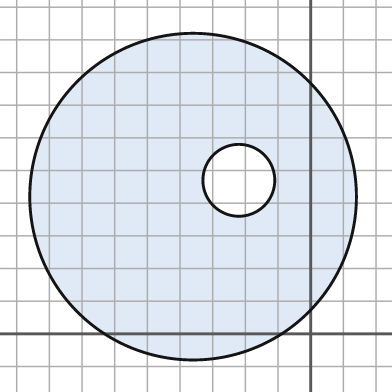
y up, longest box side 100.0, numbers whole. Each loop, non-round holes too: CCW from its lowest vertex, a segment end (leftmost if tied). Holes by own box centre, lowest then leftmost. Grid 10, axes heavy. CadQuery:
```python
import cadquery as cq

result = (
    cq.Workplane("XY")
    .moveTo(-36.0, 42.0)
    .circle(50.0)
    .moveTo(-22.0, 47.0)
    .circle(11.0)
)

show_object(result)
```